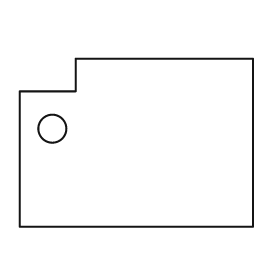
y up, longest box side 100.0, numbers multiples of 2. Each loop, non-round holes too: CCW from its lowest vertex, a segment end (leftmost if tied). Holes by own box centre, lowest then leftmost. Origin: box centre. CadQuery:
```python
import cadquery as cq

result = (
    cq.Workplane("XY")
    .moveTo(-50.0, -36.0)
    .lineTo(50.0, -36.0)
    .lineTo(50.0, 36.0)
    .lineTo(-26.0, 36.0)
    .lineTo(-26.0, 22.0)
    .lineTo(-50.0, 22.0)
    .close()
    .moveTo(-36.0, 6.0)
    .circle(6.0)
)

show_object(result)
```